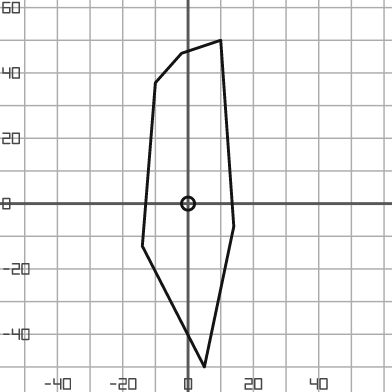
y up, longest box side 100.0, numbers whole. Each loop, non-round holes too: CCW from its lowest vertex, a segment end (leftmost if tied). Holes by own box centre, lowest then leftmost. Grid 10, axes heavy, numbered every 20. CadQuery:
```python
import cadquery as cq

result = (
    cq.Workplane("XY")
    .moveTo(5.0, -50.0)
    .lineTo(14.0, -7.0)
    .lineTo(10.0, 50.0)
    .lineTo(-2.0, 46.0)
    .lineTo(-10.0, 37.0)
    .lineTo(-14.0, -13.0)
    .close()
    .moveTo(0.0, 0.0)
    .circle(2.0)
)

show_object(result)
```